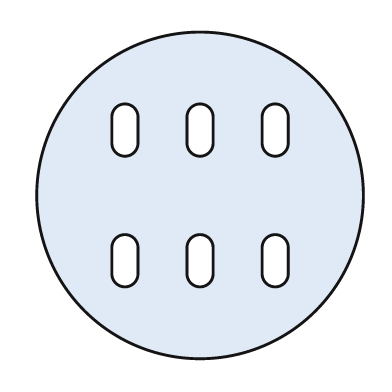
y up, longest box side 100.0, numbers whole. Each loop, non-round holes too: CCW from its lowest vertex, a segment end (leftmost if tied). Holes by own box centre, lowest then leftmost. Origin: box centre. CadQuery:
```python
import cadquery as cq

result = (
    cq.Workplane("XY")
    .moveTo(0.0, 0.0)
    .circle(50.0)
    .moveTo(-27.0, -24.0)
    .threePointArc((-23.0, -28.0), (-19.0, -24.0))
    .lineTo(-19.0, -16.0)
    .threePointArc((-23.0, -12.0), (-27.0, -16.0))
    .close()
    .moveTo(-4.0, -24.0)
    .threePointArc((0.0, -28.0), (4.0, -24.0))
    .lineTo(4.0, -16.0)
    .threePointArc((0.0, -12.0), (-4.0, -16.0))
    .close()
    .moveTo(19.0, -24.0)
    .threePointArc((23.0, -28.0), (27.0, -24.0))
    .lineTo(27.0, -16.0)
    .threePointArc((23.0, -12.0), (19.0, -16.0))
    .close()
    .moveTo(-27.0, 16.0)
    .threePointArc((-23.0, 12.0), (-19.0, 16.0))
    .lineTo(-19.0, 24.0)
    .threePointArc((-23.0, 28.0), (-27.0, 24.0))
    .close()
    .moveTo(-4.0, 16.0)
    .threePointArc((0.0, 12.0), (4.0, 16.0))
    .lineTo(4.0, 24.0)
    .threePointArc((0.0, 28.0), (-4.0, 24.0))
    .close()
    .moveTo(19.0, 16.0)
    .threePointArc((23.0, 12.0), (27.0, 16.0))
    .lineTo(27.0, 24.0)
    .threePointArc((23.0, 28.0), (19.0, 24.0))
    .close()
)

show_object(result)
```